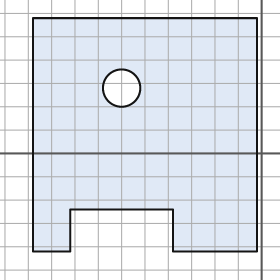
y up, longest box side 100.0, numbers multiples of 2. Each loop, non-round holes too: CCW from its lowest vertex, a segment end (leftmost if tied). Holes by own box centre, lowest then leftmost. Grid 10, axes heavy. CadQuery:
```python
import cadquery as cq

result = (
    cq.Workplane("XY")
    .moveTo(-98.0, -42.0)
    .lineTo(-82.0, -42.0)
    .lineTo(-82.0, -24.0)
    .lineTo(-38.0, -24.0)
    .lineTo(-38.0, -42.0)
    .lineTo(-2.0, -42.0)
    .lineTo(-2.0, 58.0)
    .lineTo(-98.0, 58.0)
    .close()
    .moveTo(-60.0, 28.0)
    .circle(8.0)
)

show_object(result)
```